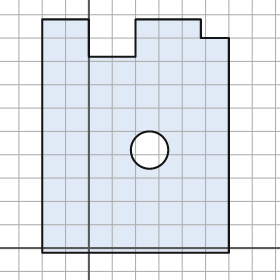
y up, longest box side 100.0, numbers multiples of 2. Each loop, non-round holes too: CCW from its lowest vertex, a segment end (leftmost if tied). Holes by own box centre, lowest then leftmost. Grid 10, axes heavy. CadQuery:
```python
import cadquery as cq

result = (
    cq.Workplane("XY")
    .moveTo(-20.0, -2.0)
    .lineTo(60.0, -2.0)
    .lineTo(60.0, 90.0)
    .lineTo(48.0, 90.0)
    .lineTo(48.0, 98.0)
    .lineTo(20.0, 98.0)
    .lineTo(20.0, 82.0)
    .lineTo(0.0, 82.0)
    .lineTo(0.0, 98.0)
    .lineTo(-20.0, 98.0)
    .close()
    .moveTo(26.0, 42.0)
    .circle(8.0)
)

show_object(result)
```